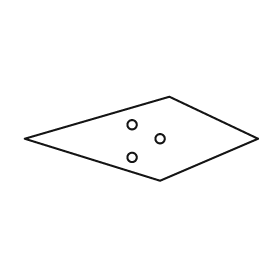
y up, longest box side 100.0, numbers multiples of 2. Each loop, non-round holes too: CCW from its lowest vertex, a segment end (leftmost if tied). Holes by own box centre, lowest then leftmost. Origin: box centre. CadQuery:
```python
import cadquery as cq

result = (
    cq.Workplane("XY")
    .moveTo(8.0, -18.0)
    .lineTo(50.0, 0.0)
    .lineTo(12.0, 18.0)
    .lineTo(-50.0, 0.0)
    .close()
    .moveTo(-4.0, -8.0)
    .circle(2.0)
    .moveTo(8.0, 0.0)
    .circle(2.0)
    .moveTo(-4.0, 6.0)
    .circle(2.0)
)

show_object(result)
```